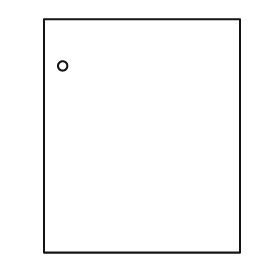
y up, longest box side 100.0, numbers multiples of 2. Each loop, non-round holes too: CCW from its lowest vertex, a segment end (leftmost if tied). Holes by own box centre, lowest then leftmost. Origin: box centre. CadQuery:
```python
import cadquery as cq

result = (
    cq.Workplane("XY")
    .moveTo(-42.0, -50.0)
    .lineTo(42.0, -50.0)
    .lineTo(42.0, 50.0)
    .lineTo(-42.0, 50.0)
    .close()
    .moveTo(-34.0, 30.0)
    .circle(2.0)
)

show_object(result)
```